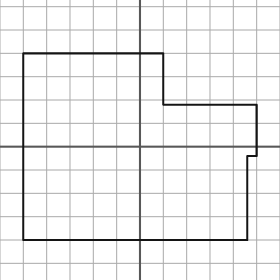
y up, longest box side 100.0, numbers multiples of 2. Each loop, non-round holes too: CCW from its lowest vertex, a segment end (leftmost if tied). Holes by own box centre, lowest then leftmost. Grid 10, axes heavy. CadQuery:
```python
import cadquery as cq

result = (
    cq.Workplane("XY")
    .moveTo(-50.0, -40.0)
    .lineTo(46.0, -40.0)
    .lineTo(46.0, -4.0)
    .lineTo(50.0, -4.0)
    .lineTo(50.0, 18.0)
    .lineTo(10.0, 18.0)
    .lineTo(10.0, 40.0)
    .lineTo(-50.0, 40.0)
    .close()
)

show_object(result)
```